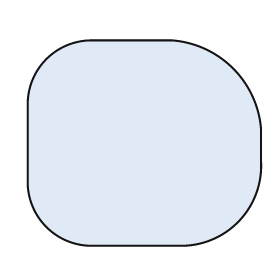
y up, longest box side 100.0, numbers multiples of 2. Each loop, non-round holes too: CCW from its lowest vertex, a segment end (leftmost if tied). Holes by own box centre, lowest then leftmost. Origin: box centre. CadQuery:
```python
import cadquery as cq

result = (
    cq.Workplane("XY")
    .moveTo(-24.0, -44.0)
    .lineTo(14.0, -44.0)
    .threePointArc((40.0, -34.0), (50.0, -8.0))
    .lineTo(50.0, 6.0)
    .threePointArc((38.0, 32.0), (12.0, 44.0))
    .lineTo(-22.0, 44.0)
    .threePointArc((-42.0, 36.0), (-50.0, 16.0))
    .lineTo(-50.0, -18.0)
    .threePointArc((-42.0, -36.0), (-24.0, -44.0))
    .close()
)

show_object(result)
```